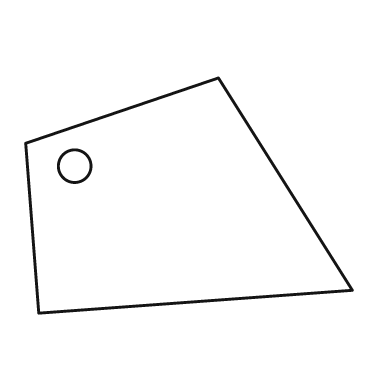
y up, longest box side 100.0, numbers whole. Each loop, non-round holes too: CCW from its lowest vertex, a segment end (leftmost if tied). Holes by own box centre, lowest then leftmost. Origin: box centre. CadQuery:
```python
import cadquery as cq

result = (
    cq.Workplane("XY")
    .moveTo(-46.0, -36.0)
    .lineTo(50.0, -29.0)
    .lineTo(9.0, 36.0)
    .lineTo(-50.0, 16.0)
    .close()
    .moveTo(-35.0, 9.0)
    .circle(5.0)
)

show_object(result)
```